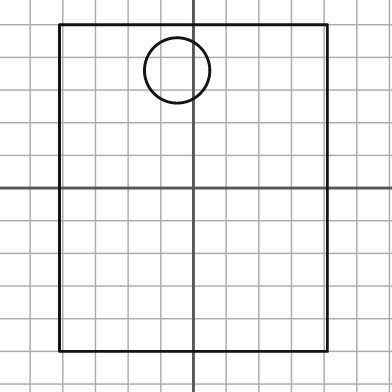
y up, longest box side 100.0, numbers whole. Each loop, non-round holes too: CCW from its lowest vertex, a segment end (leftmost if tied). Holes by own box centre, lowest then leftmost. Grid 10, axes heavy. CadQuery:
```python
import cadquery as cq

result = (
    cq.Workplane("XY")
    .moveTo(-41.0, -50.0)
    .lineTo(41.0, -50.0)
    .lineTo(41.0, 50.0)
    .lineTo(-41.0, 50.0)
    .close()
    .moveTo(-5.0, 36.0)
    .circle(10.0)
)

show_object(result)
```